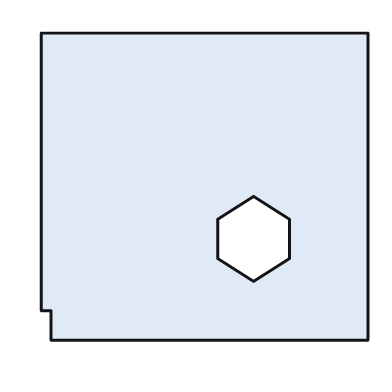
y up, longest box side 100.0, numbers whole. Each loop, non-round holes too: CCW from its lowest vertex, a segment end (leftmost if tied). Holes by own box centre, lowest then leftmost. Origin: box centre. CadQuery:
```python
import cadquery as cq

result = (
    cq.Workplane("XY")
    .moveTo(-47.0, -47.0)
    .lineTo(50.0, -47.0)
    .lineTo(50.0, 47.0)
    .lineTo(-50.0, 47.0)
    .lineTo(-50.0, -38.0)
    .lineTo(-47.0, -38.0)
    .close()
    .moveTo(15.0, -29.0)
    .lineTo(26.0, -22.0)
    .lineTo(26.0, -10.0)
    .lineTo(15.0, -3.0)
    .lineTo(4.0, -10.0)
    .lineTo(4.0, -22.0)
    .close()
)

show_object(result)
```